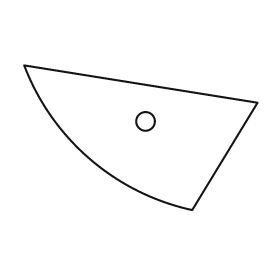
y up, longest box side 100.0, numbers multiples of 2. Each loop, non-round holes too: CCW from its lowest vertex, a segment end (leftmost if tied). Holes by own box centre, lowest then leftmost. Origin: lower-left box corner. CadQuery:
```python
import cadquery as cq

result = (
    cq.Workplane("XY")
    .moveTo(72.0, 0.0)
    .lineTo(100.0, 46.0)
    .lineTo(0.0, 62.0)
    .threePointArc((28.0, 22.0), (72.0, 0.0))
    .close()
    .moveTo(52.0, 38.0)
    .circle(4.0)
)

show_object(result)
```